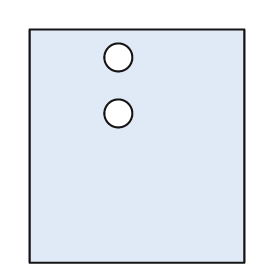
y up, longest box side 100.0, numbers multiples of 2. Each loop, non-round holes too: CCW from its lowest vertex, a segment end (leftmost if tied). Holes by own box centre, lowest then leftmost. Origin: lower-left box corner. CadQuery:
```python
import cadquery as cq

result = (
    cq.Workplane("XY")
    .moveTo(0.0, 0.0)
    .lineTo(92.0, 0.0)
    .lineTo(92.0, 100.0)
    .lineTo(0.0, 100.0)
    .close()
    .moveTo(38.0, 64.0)
    .circle(6.0)
    .moveTo(38.0, 88.0)
    .circle(6.0)
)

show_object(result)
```